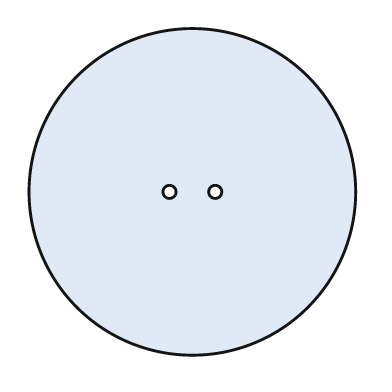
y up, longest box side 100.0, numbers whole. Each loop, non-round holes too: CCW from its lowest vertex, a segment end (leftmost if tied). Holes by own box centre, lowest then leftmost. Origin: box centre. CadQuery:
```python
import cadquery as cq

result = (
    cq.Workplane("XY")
    .moveTo(0.0, 0.0)
    .circle(50.0)
    .moveTo(-7.0, 0.0)
    .circle(2.0)
    .moveTo(7.0, 0.0)
    .circle(2.0)
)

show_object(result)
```